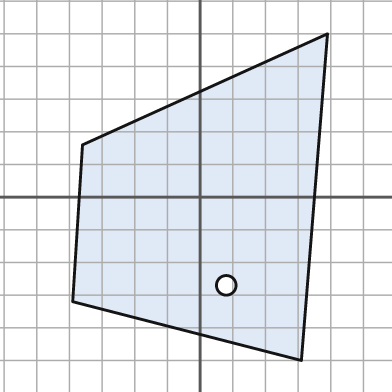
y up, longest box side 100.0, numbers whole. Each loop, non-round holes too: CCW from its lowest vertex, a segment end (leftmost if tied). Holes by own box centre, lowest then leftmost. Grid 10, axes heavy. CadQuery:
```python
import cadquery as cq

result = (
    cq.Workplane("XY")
    .moveTo(31.0, -50.0)
    .lineTo(39.0, 50.0)
    .lineTo(-36.0, 16.0)
    .lineTo(-39.0, -32.0)
    .close()
    .moveTo(8.0, -27.0)
    .circle(3.0)
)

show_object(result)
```